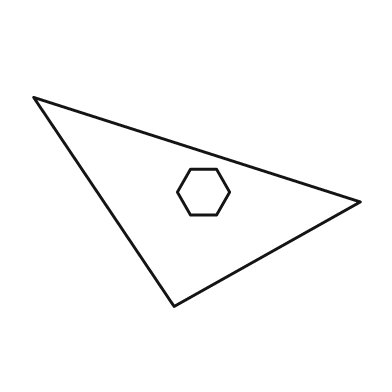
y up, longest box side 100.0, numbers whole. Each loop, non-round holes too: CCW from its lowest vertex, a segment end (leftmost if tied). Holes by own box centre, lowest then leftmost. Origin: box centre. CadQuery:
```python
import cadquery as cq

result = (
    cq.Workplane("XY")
    .moveTo(-7.0, -32.0)
    .lineTo(50.0, 0.0)
    .lineTo(-50.0, 32.0)
    .close()
    .moveTo(-2.0, -4.0)
    .lineTo(6.0, -4.0)
    .lineTo(10.0, 3.0)
    .lineTo(6.0, 10.0)
    .lineTo(-2.0, 10.0)
    .lineTo(-6.0, 3.0)
    .close()
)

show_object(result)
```